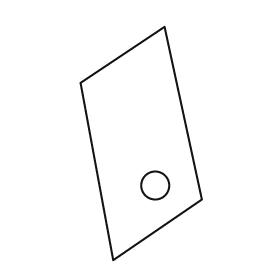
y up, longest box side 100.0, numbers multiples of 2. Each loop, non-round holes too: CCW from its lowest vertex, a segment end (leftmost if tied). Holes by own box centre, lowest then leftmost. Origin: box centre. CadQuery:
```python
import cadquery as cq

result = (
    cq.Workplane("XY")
    .moveTo(-12.0, -50.0)
    .lineTo(26.0, -24.0)
    .lineTo(10.0, 50.0)
    .lineTo(-26.0, 26.0)
    .close()
    .moveTo(6.0, -18.0)
    .circle(6.0)
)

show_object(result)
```